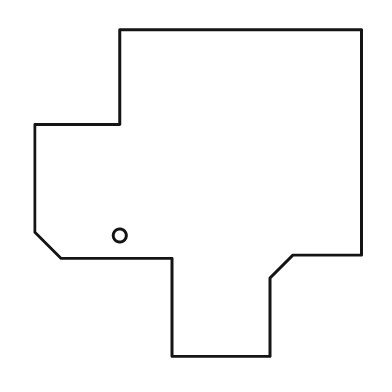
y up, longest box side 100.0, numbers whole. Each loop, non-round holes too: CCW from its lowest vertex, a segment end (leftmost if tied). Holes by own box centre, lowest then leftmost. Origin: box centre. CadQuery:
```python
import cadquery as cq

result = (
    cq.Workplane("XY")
    .moveTo(-8.0, -50.0)
    .lineTo(22.0, -50.0)
    .lineTo(22.0, -26.0)
    .lineTo(29.0, -19.0)
    .lineTo(50.0, -19.0)
    .lineTo(50.0, 50.0)
    .lineTo(-24.0, 50.0)
    .lineTo(-24.0, 21.0)
    .lineTo(-50.0, 21.0)
    .lineTo(-50.0, -12.0)
    .lineTo(-42.0, -20.0)
    .lineTo(-8.0, -20.0)
    .close()
    .moveTo(-24.0, -13.0)
    .circle(2.0)
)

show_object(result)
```